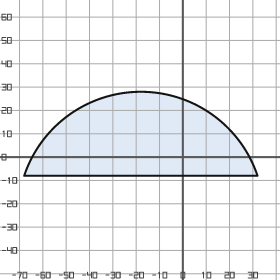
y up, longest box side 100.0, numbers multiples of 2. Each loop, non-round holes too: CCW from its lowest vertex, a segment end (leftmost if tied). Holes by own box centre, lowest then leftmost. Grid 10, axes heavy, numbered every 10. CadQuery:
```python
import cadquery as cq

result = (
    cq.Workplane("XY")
    .moveTo(-68.0, -8.0)
    .lineTo(32.0, -8.0)
    .threePointArc((-18.0, 28.0), (-68.0, -8.0))
    .close()
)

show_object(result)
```